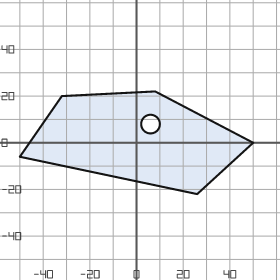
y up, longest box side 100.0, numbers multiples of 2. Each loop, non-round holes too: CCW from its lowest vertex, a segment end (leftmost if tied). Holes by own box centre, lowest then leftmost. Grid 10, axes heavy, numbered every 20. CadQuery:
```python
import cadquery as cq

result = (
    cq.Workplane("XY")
    .moveTo(26.0, -22.0)
    .lineTo(50.0, 0.0)
    .lineTo(8.0, 22.0)
    .lineTo(-32.0, 20.0)
    .lineTo(-50.0, -6.0)
    .close()
    .moveTo(6.0, 8.0)
    .circle(4.0)
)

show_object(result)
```